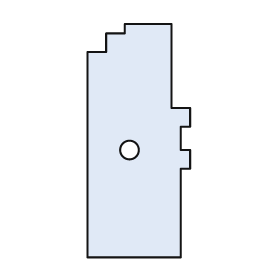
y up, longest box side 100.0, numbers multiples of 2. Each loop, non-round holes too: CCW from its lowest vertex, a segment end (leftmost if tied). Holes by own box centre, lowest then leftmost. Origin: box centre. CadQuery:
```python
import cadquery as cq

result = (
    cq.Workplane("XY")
    .moveTo(-22.0, -50.0)
    .lineTo(18.0, -50.0)
    .lineTo(18.0, -12.0)
    .lineTo(22.0, -12.0)
    .lineTo(22.0, -4.0)
    .lineTo(18.0, -4.0)
    .lineTo(18.0, 6.0)
    .lineTo(22.0, 6.0)
    .lineTo(22.0, 14.0)
    .lineTo(14.0, 14.0)
    .lineTo(14.0, 50.0)
    .lineTo(-6.0, 50.0)
    .lineTo(-6.0, 46.0)
    .lineTo(-14.0, 46.0)
    .lineTo(-14.0, 38.0)
    .lineTo(-22.0, 38.0)
    .close()
    .moveTo(-4.0, -4.0)
    .circle(4.0)
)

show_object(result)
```